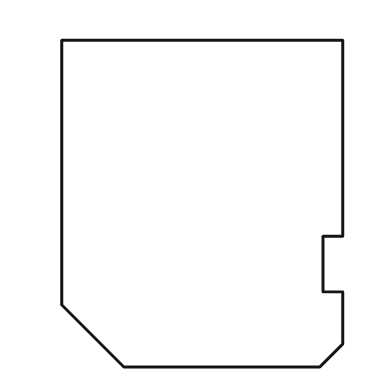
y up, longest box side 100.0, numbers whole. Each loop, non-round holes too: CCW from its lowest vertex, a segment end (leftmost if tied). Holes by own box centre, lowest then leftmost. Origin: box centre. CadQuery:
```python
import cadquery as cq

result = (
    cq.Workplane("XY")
    .moveTo(-24.0, -50.0)
    .lineTo(36.0, -50.0)
    .lineTo(43.0, -43.0)
    .lineTo(43.0, -27.0)
    .lineTo(37.0, -27.0)
    .lineTo(37.0, -10.0)
    .lineTo(43.0, -10.0)
    .lineTo(43.0, 50.0)
    .lineTo(-43.0, 50.0)
    .lineTo(-43.0, -31.0)
    .close()
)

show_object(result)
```